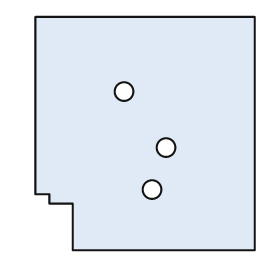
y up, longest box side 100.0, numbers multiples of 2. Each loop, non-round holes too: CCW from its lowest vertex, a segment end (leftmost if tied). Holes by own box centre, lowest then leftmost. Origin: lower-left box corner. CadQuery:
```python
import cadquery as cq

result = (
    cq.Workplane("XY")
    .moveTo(16.0, 0.0)
    .lineTo(94.0, 0.0)
    .lineTo(94.0, 100.0)
    .lineTo(0.0, 100.0)
    .lineTo(0.0, 24.0)
    .lineTo(6.0, 24.0)
    .lineTo(6.0, 20.0)
    .lineTo(16.0, 20.0)
    .close()
    .moveTo(50.0, 26.0)
    .circle(4.0)
    .moveTo(56.0, 44.0)
    .circle(4.0)
    .moveTo(38.0, 68.0)
    .circle(4.0)
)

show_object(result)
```